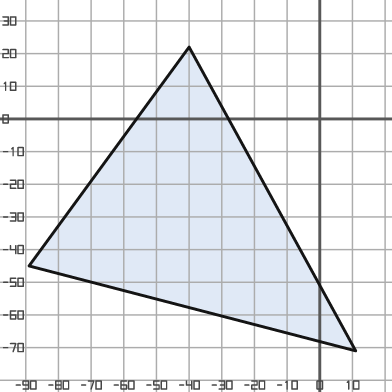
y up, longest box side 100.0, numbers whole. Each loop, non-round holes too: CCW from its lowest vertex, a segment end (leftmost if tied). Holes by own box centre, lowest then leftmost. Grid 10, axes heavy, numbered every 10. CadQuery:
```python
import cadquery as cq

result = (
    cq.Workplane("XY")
    .moveTo(11.0, -71.0)
    .lineTo(-40.0, 22.0)
    .lineTo(-89.0, -45.0)
    .close()
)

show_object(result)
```